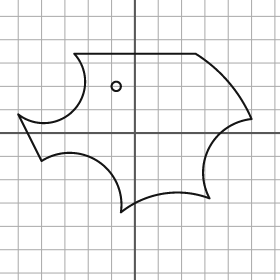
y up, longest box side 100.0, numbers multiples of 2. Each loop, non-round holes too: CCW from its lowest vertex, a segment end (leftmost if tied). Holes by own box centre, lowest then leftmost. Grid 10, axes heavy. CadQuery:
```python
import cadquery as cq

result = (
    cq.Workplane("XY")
    .moveTo(-6.0, -34.0)
    .threePointArc((12.0, -26.0), (32.0, -28.0))
    .threePointArc((32.0, -6.0), (50.0, 6.0))
    .threePointArc((40.0, 22.0), (26.0, 34.0))
    .lineTo(-26.0, 34.0)
    .threePointArc((-26.0, 10.0), (-50.0, 8.0))
    .lineTo(-40.0, -12.0)
    .threePointArc((-16.0, -12.0), (-6.0, -34.0))
    .close()
    .moveTo(-8.0, 20.0)
    .circle(2.0)
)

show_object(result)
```